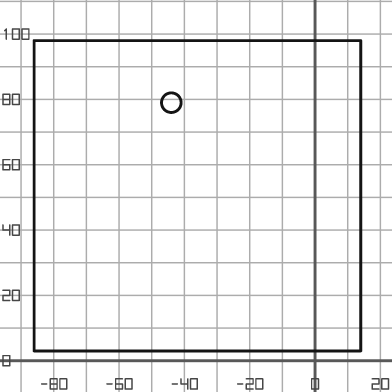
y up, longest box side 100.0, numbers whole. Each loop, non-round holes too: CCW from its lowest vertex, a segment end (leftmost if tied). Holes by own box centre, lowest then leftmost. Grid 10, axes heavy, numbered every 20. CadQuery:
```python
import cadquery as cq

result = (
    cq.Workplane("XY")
    .moveTo(-86.0, 3.0)
    .lineTo(14.0, 3.0)
    .lineTo(14.0, 98.0)
    .lineTo(-86.0, 98.0)
    .close()
    .moveTo(-44.0, 79.0)
    .circle(3.0)
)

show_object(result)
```